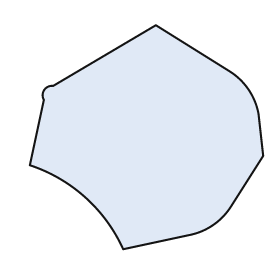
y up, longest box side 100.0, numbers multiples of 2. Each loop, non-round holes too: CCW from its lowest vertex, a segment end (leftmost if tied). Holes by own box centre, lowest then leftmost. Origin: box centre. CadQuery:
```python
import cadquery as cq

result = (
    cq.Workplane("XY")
    .moveTo(-10.0, -48.0)
    .lineTo(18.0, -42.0)
    .threePointArc((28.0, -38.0), (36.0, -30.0))
    .lineTo(50.0, -8.0)
    .lineTo(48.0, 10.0)
    .threePointArc((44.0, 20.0), (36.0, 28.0))
    .lineTo(4.0, 48.0)
    .lineTo(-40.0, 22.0)
    .threePointArc((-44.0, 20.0), (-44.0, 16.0))
    .lineTo(-50.0, -12.0)
    .threePointArc((-26.0, -26.0), (-10.0, -48.0))
    .close()
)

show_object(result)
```